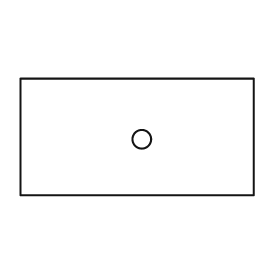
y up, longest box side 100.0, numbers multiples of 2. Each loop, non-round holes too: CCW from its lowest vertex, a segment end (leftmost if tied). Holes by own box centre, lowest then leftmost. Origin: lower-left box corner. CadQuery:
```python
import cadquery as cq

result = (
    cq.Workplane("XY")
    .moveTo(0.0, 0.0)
    .lineTo(100.0, 0.0)
    .lineTo(100.0, 50.0)
    .lineTo(0.0, 50.0)
    .close()
    .moveTo(52.0, 24.0)
    .circle(4.0)
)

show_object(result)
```